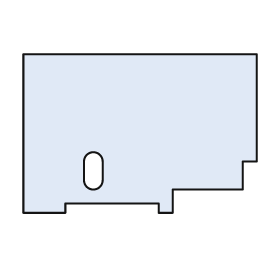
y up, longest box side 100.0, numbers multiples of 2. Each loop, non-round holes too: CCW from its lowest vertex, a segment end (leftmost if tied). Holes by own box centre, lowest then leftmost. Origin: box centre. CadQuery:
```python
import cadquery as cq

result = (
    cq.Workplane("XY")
    .moveTo(-50.0, -34.0)
    .lineTo(-32.0, -34.0)
    .lineTo(-32.0, -30.0)
    .lineTo(8.0, -30.0)
    .lineTo(8.0, -34.0)
    .lineTo(14.0, -34.0)
    .lineTo(14.0, -24.0)
    .lineTo(44.0, -24.0)
    .lineTo(44.0, -12.0)
    .lineTo(50.0, -12.0)
    .lineTo(50.0, 34.0)
    .lineTo(-50.0, 34.0)
    .close()
    .moveTo(-24.0, -20.0)
    .threePointArc((-20.0, -24.0), (-16.0, -20.0))
    .lineTo(-16.0, -12.0)
    .threePointArc((-20.0, -8.0), (-24.0, -12.0))
    .close()
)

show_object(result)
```